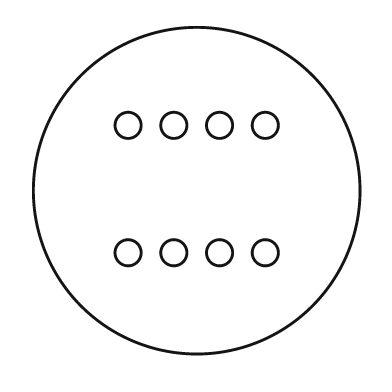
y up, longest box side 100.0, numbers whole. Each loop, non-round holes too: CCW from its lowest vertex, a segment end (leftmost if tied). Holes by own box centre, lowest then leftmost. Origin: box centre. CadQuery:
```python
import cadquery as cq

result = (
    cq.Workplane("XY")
    .moveTo(0.0, 0.0)
    .circle(50.0)
    .moveTo(-21.0, -19.0)
    .circle(4.0)
    .moveTo(-7.0, -19.0)
    .circle(4.0)
    .moveTo(7.0, -19.0)
    .circle(4.0)
    .moveTo(21.0, -19.0)
    .circle(4.0)
    .moveTo(-21.0, 20.0)
    .circle(4.0)
    .moveTo(-7.0, 20.0)
    .circle(4.0)
    .moveTo(7.0, 20.0)
    .circle(4.0)
    .moveTo(21.0, 20.0)
    .circle(4.0)
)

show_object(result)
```